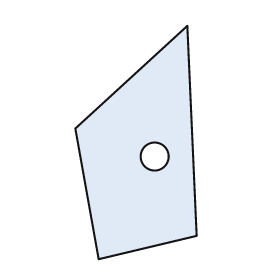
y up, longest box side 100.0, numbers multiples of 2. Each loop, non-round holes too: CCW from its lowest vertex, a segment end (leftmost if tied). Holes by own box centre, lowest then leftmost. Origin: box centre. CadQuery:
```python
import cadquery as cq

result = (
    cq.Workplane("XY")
    .moveTo(-16.0, -50.0)
    .lineTo(26.0, -40.0)
    .lineTo(22.0, 50.0)
    .lineTo(-26.0, 6.0)
    .close()
    .moveTo(8.0, -6.0)
    .circle(6.0)
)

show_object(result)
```